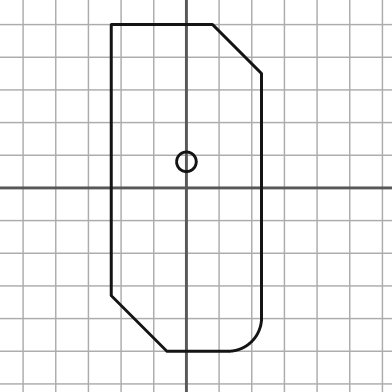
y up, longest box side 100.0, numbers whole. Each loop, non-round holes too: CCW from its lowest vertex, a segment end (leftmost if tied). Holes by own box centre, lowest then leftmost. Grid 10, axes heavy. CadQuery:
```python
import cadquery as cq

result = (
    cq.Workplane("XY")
    .moveTo(-6.0, -50.0)
    .lineTo(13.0, -50.0)
    .threePointArc((20.0, -47.0), (23.0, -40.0))
    .lineTo(23.0, 35.0)
    .lineTo(8.0, 50.0)
    .lineTo(-23.0, 50.0)
    .lineTo(-23.0, -33.0)
    .close()
    .moveTo(0.0, 8.0)
    .circle(3.0)
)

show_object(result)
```